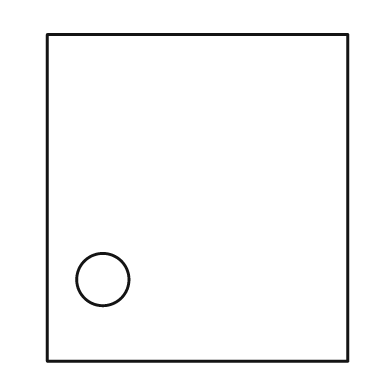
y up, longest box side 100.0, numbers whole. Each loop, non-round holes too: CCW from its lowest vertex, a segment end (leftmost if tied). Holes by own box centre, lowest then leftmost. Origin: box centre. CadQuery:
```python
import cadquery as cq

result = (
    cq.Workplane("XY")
    .moveTo(-46.0, -50.0)
    .lineTo(46.0, -50.0)
    .lineTo(46.0, 50.0)
    .lineTo(-46.0, 50.0)
    .close()
    .moveTo(-29.0, -25.0)
    .circle(8.0)
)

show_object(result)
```